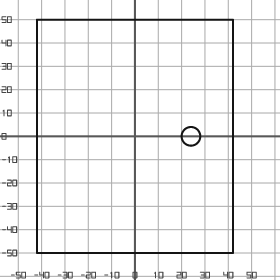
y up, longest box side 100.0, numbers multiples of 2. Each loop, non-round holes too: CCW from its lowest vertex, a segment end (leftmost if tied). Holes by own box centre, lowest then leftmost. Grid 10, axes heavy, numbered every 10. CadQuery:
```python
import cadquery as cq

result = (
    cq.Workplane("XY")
    .moveTo(-42.0, -50.0)
    .lineTo(42.0, -50.0)
    .lineTo(42.0, 50.0)
    .lineTo(-42.0, 50.0)
    .close()
    .moveTo(24.0, 0.0)
    .circle(4.0)
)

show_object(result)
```